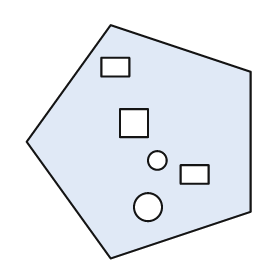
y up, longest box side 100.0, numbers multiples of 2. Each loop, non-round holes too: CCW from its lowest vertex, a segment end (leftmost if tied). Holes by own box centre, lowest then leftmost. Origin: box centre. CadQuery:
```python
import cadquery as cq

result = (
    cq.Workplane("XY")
    .moveTo(-12.0, -50.0)
    .lineTo(48.0, -30.0)
    .lineTo(48.0, 30.0)
    .lineTo(-12.0, 50.0)
    .lineTo(-48.0, 0.0)
    .close()
    .moveTo(4.0, -28.0)
    .circle(6.0)
    .moveTo(18.0, -18.0)
    .lineTo(30.0, -18.0)
    .lineTo(30.0, -10.0)
    .lineTo(18.0, -10.0)
    .close()
    .moveTo(8.0, -8.0)
    .circle(4.0)
    .moveTo(-8.0, 2.0)
    .lineTo(4.0, 2.0)
    .lineTo(4.0, 14.0)
    .lineTo(-8.0, 14.0)
    .close()
    .moveTo(-16.0, 28.0)
    .lineTo(-4.0, 28.0)
    .lineTo(-4.0, 36.0)
    .lineTo(-16.0, 36.0)
    .close()
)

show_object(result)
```